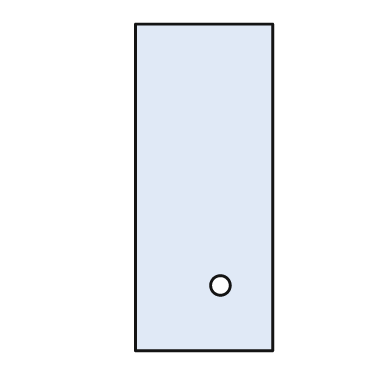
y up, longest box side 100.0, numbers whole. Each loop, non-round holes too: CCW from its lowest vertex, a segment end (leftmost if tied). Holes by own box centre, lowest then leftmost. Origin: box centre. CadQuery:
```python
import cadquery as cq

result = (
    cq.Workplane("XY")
    .moveTo(-21.0, -50.0)
    .lineTo(21.0, -50.0)
    .lineTo(21.0, 50.0)
    .lineTo(-21.0, 50.0)
    .close()
    .moveTo(5.0, -30.0)
    .circle(3.0)
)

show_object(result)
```